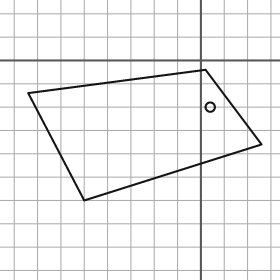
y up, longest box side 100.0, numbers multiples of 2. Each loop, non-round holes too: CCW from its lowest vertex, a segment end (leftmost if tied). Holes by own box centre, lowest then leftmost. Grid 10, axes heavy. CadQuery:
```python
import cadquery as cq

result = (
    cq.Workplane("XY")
    .moveTo(-50.0, -60.0)
    .lineTo(26.0, -36.0)
    .lineTo(2.0, -4.0)
    .lineTo(-74.0, -14.0)
    .close()
    .moveTo(4.0, -20.0)
    .circle(2.0)
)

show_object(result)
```